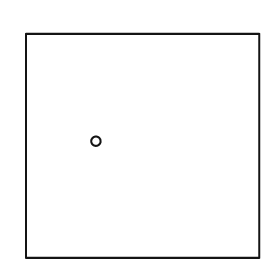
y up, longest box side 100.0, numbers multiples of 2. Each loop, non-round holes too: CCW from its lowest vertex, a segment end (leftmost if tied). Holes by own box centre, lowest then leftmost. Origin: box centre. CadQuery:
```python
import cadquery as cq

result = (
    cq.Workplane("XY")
    .moveTo(-50.0, -48.0)
    .lineTo(50.0, -48.0)
    .lineTo(50.0, 48.0)
    .lineTo(-50.0, 48.0)
    .close()
    .moveTo(-20.0, 2.0)
    .circle(2.0)
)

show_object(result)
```